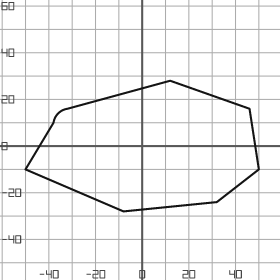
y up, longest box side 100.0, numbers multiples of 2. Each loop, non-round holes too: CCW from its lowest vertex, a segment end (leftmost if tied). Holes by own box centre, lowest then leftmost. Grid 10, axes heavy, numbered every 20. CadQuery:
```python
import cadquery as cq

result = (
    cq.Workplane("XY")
    .moveTo(-8.0, -28.0)
    .lineTo(32.0, -24.0)
    .lineTo(50.0, -10.0)
    .lineTo(46.0, 16.0)
    .lineTo(12.0, 28.0)
    .lineTo(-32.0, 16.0)
    .threePointArc((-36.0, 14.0), (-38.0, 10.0))
    .lineTo(-50.0, -10.0)
    .close()
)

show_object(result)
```